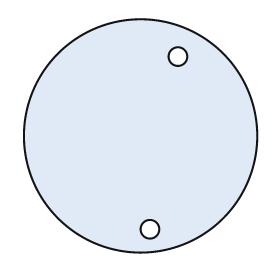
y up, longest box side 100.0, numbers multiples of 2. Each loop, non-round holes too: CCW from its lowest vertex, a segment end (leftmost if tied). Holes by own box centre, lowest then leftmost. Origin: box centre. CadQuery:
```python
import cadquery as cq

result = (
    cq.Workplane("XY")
    .moveTo(0.0, 0.0)
    .circle(50.0)
    .moveTo(4.0, -40.0)
    .circle(4.0)
    .moveTo(16.0, 34.0)
    .circle(4.0)
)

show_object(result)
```